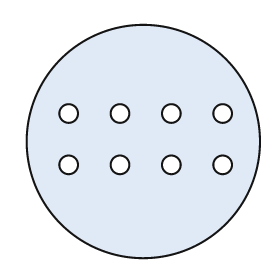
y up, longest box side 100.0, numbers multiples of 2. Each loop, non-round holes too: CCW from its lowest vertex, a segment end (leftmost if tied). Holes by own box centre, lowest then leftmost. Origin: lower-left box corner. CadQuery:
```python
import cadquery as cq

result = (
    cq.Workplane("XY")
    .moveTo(50.0, 50.0)
    .circle(50.0)
    .moveTo(18.0, 40.0)
    .circle(4.0)
    .moveTo(40.0, 40.0)
    .circle(4.0)
    .moveTo(62.0, 40.0)
    .circle(4.0)
    .moveTo(84.0, 40.0)
    .circle(4.0)
    .moveTo(18.0, 62.0)
    .circle(4.0)
    .moveTo(40.0, 62.0)
    .circle(4.0)
    .moveTo(62.0, 62.0)
    .circle(4.0)
    .moveTo(84.0, 62.0)
    .circle(4.0)
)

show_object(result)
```